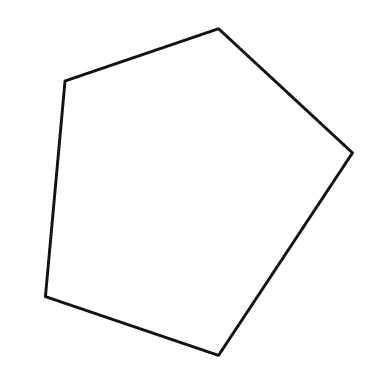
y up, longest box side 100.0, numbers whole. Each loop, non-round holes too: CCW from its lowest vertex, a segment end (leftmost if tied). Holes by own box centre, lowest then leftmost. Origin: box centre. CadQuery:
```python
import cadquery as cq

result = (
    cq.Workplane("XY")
    .moveTo(6.0, -50.0)
    .lineTo(47.0, 12.0)
    .lineTo(6.0, 50.0)
    .lineTo(-41.0, 34.0)
    .lineTo(-47.0, -32.0)
    .close()
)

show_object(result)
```